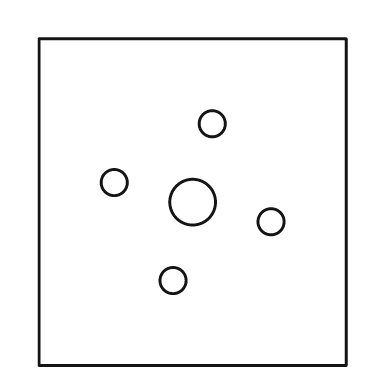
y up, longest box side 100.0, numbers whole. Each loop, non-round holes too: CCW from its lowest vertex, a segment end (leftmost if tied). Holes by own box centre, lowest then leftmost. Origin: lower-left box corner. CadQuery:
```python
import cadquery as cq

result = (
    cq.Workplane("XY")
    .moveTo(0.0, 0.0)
    .lineTo(94.0, 0.0)
    .lineTo(94.0, 100.0)
    .lineTo(0.0, 100.0)
    .close()
    .moveTo(41.0, 26.0)
    .circle(4.0)
    .moveTo(71.0, 44.0)
    .circle(4.0)
    .moveTo(47.0, 50.0)
    .circle(7.0)
    .moveTo(23.0, 56.0)
    .circle(4.0)
    .moveTo(53.0, 74.0)
    .circle(4.0)
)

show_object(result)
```